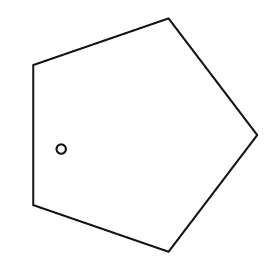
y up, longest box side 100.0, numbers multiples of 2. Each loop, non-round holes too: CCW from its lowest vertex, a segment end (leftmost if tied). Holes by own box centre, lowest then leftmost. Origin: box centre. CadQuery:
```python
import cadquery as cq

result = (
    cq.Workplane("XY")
    .moveTo(10.0, -50.0)
    .lineTo(48.0, 0.0)
    .lineTo(10.0, 50.0)
    .lineTo(-48.0, 30.0)
    .lineTo(-48.0, -30.0)
    .close()
    .moveTo(-36.0, -6.0)
    .circle(2.0)
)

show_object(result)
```